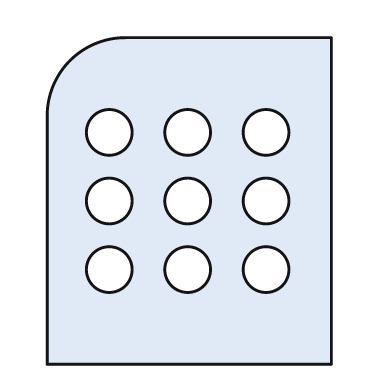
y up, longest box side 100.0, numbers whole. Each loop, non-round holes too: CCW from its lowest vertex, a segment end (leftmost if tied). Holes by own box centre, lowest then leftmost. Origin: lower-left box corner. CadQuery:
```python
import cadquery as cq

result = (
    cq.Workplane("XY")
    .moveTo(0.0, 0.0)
    .lineTo(87.0, 0.0)
    .lineTo(87.0, 100.0)
    .lineTo(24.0, 100.0)
    .threePointArc((7.0, 93.0), (0.0, 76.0))
    .close()
    .moveTo(19.0, 29.0)
    .circle(7.0)
    .moveTo(43.0, 29.0)
    .circle(7.0)
    .moveTo(67.0, 29.0)
    .circle(7.0)
    .moveTo(19.0, 50.0)
    .circle(7.0)
    .moveTo(43.0, 50.0)
    .circle(7.0)
    .moveTo(67.0, 50.0)
    .circle(7.0)
    .moveTo(19.0, 71.0)
    .circle(7.0)
    .moveTo(43.0, 71.0)
    .circle(7.0)
    .moveTo(67.0, 71.0)
    .circle(7.0)
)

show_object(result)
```